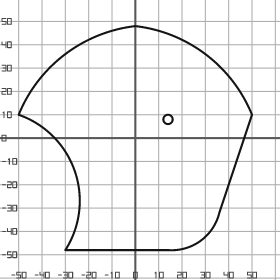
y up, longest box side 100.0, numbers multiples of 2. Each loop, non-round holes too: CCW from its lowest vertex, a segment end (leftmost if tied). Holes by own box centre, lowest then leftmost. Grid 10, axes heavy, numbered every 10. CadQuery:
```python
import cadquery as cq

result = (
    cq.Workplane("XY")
    .moveTo(-30.0, -48.0)
    .lineTo(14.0, -48.0)
    .threePointArc((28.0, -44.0), (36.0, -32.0))
    .lineTo(50.0, 10.0)
    .threePointArc((30.0, 36.0), (0.0, 48.0))
    .threePointArc((-30.0, 36.0), (-50.0, 10.0))
    .threePointArc((-26.0, -14.0), (-30.0, -48.0))
    .close()
    .moveTo(14.0, 8.0)
    .circle(2.0)
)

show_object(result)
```